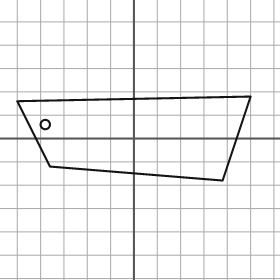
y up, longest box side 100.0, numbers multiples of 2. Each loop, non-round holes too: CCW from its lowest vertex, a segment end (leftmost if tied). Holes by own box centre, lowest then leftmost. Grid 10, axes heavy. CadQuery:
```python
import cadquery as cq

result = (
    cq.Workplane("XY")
    .moveTo(38.0, -18.0)
    .lineTo(50.0, 18.0)
    .lineTo(-50.0, 16.0)
    .lineTo(-36.0, -12.0)
    .close()
    .moveTo(-38.0, 6.0)
    .circle(2.0)
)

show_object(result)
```